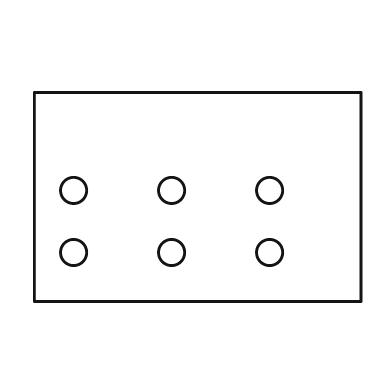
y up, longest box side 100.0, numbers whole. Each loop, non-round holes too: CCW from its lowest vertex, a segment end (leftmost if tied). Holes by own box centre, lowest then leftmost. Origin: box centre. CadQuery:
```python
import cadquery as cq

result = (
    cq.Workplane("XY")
    .moveTo(-50.0, -32.0)
    .lineTo(50.0, -32.0)
    .lineTo(50.0, 32.0)
    .lineTo(-50.0, 32.0)
    .close()
    .moveTo(-38.0, -17.0)
    .circle(4.0)
    .moveTo(-8.0, -17.0)
    .circle(4.0)
    .moveTo(22.0, -17.0)
    .circle(4.0)
    .moveTo(-38.0, 2.0)
    .circle(4.0)
    .moveTo(-8.0, 2.0)
    .circle(4.0)
    .moveTo(22.0, 2.0)
    .circle(4.0)
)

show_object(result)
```